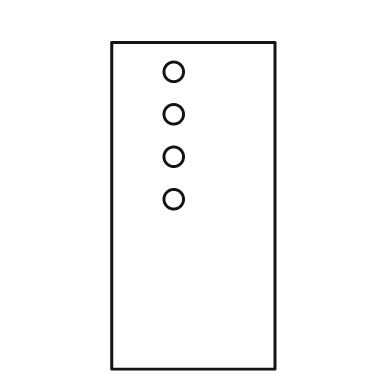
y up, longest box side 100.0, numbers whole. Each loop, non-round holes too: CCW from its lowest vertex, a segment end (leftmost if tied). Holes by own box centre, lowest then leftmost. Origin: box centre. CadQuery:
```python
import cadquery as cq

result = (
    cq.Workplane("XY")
    .moveTo(-25.0, -50.0)
    .lineTo(25.0, -50.0)
    .lineTo(25.0, 50.0)
    .lineTo(-25.0, 50.0)
    .close()
    .moveTo(-6.0, 2.0)
    .circle(3.0)
    .moveTo(-6.0, 15.0)
    .circle(3.0)
    .moveTo(-6.0, 28.0)
    .circle(3.0)
    .moveTo(-6.0, 41.0)
    .circle(3.0)
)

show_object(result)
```